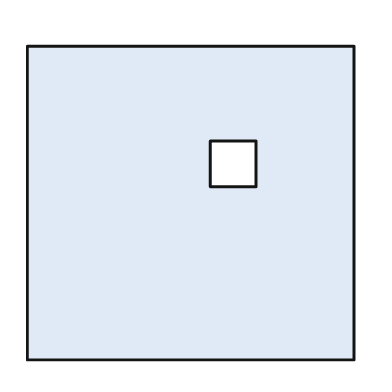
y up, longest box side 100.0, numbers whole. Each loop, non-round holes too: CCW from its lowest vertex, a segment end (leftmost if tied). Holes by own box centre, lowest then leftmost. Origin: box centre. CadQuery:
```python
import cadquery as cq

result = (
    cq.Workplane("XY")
    .moveTo(-50.0, -48.0)
    .lineTo(50.0, -48.0)
    .lineTo(50.0, 48.0)
    .lineTo(-50.0, 48.0)
    .close()
    .moveTo(6.0, 5.0)
    .lineTo(20.0, 5.0)
    .lineTo(20.0, 19.0)
    .lineTo(6.0, 19.0)
    .close()
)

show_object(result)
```